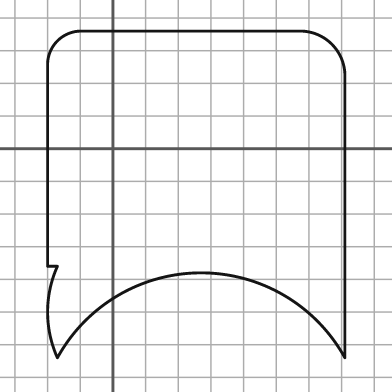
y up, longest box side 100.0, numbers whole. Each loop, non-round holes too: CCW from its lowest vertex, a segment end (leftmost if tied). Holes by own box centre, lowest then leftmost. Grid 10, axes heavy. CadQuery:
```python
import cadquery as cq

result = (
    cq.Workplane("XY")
    .moveTo(-17.0, -64.0)
    .threePointArc((27.0, -38.0), (71.0, -64.0))
    .lineTo(71.0, 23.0)
    .threePointArc((67.0, 32.0), (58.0, 36.0))
    .lineTo(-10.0, 36.0)
    .threePointArc((-17.0, 33.0), (-20.0, 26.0))
    .lineTo(-20.0, -36.0)
    .lineTo(-17.0, -36.0)
    .threePointArc((-20.0, -50.0), (-17.0, -64.0))
    .close()
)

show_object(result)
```